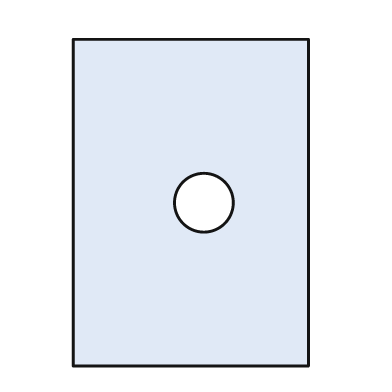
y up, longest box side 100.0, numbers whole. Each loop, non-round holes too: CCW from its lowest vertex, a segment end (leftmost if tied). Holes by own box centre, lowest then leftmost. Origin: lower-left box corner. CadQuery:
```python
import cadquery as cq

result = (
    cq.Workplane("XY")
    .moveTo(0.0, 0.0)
    .lineTo(72.0, 0.0)
    .lineTo(72.0, 100.0)
    .lineTo(0.0, 100.0)
    .close()
    .moveTo(40.0, 50.0)
    .circle(9.0)
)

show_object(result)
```